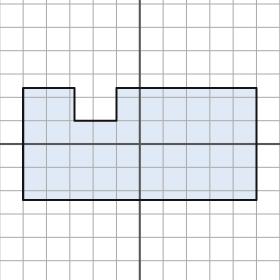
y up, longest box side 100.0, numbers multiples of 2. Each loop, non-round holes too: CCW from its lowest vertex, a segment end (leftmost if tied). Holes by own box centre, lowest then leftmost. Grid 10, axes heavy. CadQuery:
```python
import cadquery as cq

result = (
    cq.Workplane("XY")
    .moveTo(-50.0, -24.0)
    .lineTo(50.0, -24.0)
    .lineTo(50.0, 24.0)
    .lineTo(-10.0, 24.0)
    .lineTo(-10.0, 10.0)
    .lineTo(-28.0, 10.0)
    .lineTo(-28.0, 24.0)
    .lineTo(-50.0, 24.0)
    .close()
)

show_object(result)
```